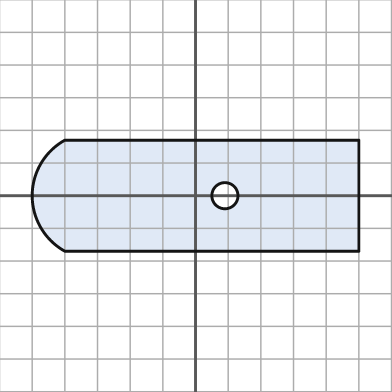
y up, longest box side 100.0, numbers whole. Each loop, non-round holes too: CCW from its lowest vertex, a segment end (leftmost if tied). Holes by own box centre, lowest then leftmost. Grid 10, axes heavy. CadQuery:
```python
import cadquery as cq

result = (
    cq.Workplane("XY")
    .moveTo(-40.0, -17.0)
    .lineTo(50.0, -17.0)
    .lineTo(50.0, 17.0)
    .lineTo(-40.0, 17.0)
    .threePointArc((-50.0, 0.0), (-40.0, -17.0))
    .close()
    .moveTo(9.0, 0.0)
    .circle(4.0)
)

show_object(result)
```